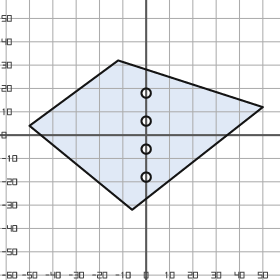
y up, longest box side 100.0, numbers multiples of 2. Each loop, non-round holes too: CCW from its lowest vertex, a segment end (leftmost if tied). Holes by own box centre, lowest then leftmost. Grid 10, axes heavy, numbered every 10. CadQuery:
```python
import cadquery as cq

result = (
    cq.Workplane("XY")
    .moveTo(-6.0, -32.0)
    .lineTo(50.0, 12.0)
    .lineTo(-12.0, 32.0)
    .lineTo(-50.0, 4.0)
    .close()
    .moveTo(0.0, -18.0)
    .circle(2.0)
    .moveTo(0.0, -6.0)
    .circle(2.0)
    .moveTo(0.0, 6.0)
    .circle(2.0)
    .moveTo(0.0, 18.0)
    .circle(2.0)
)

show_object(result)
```